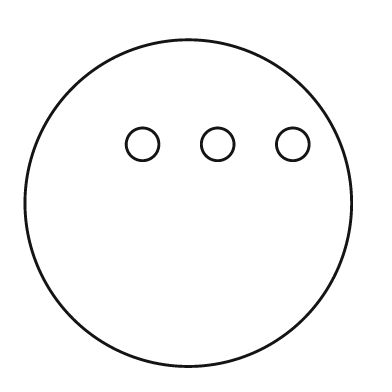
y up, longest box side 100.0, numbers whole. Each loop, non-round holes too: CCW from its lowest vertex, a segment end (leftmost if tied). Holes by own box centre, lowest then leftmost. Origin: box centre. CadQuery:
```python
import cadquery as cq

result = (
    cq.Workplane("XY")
    .moveTo(0.0, 0.0)
    .circle(50.0)
    .moveTo(-14.0, 18.0)
    .circle(5.0)
    .moveTo(9.0, 18.0)
    .circle(5.0)
    .moveTo(32.0, 18.0)
    .circle(5.0)
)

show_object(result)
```